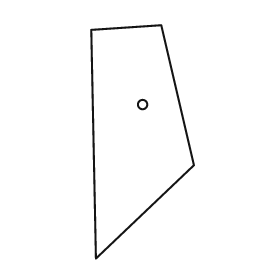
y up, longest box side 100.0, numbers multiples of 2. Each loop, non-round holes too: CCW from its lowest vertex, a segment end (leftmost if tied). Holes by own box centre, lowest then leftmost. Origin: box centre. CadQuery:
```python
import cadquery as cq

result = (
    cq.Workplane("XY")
    .moveTo(-20.0, -50.0)
    .lineTo(22.0, -10.0)
    .lineTo(8.0, 50.0)
    .lineTo(-22.0, 48.0)
    .close()
    .moveTo(0.0, 16.0)
    .circle(2.0)
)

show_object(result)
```